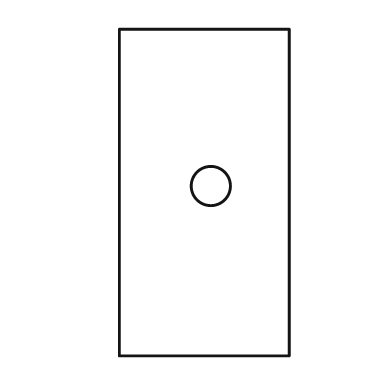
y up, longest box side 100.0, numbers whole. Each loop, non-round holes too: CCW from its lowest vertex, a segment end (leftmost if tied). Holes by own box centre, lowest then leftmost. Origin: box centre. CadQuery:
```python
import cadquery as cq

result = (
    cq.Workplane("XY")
    .moveTo(-26.0, -50.0)
    .lineTo(26.0, -50.0)
    .lineTo(26.0, 50.0)
    .lineTo(-26.0, 50.0)
    .close()
    .moveTo(2.0, 2.0)
    .circle(6.0)
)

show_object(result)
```